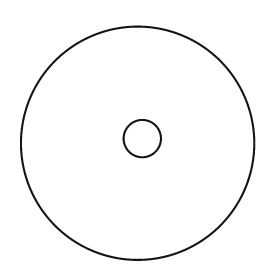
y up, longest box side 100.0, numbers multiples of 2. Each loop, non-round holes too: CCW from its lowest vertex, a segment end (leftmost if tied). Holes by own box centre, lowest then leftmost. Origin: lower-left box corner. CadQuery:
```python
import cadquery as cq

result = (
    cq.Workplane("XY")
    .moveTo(50.0, 50.0)
    .circle(50.0)
    .moveTo(52.0, 52.0)
    .circle(8.0)
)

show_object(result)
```